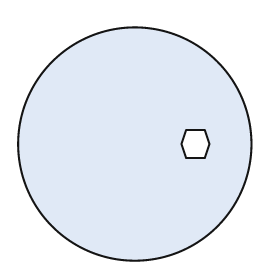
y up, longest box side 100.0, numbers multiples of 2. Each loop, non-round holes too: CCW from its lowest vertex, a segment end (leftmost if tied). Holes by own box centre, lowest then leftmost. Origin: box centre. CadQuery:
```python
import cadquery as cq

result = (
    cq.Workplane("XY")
    .moveTo(0.0, 0.0)
    .circle(50.0)
    .moveTo(22.0, -6.0)
    .lineTo(30.0, -6.0)
    .lineTo(32.0, 0.0)
    .lineTo(30.0, 6.0)
    .lineTo(22.0, 6.0)
    .lineTo(20.0, 0.0)
    .close()
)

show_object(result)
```